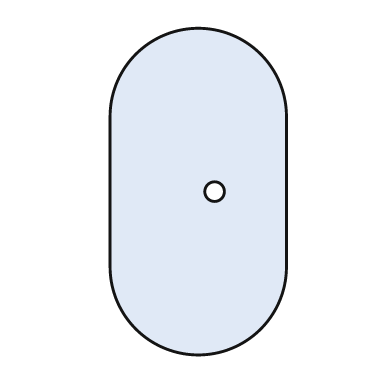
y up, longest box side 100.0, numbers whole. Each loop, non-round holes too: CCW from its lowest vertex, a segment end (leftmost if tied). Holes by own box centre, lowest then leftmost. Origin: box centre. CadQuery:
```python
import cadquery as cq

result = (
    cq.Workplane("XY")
    .moveTo(-27.0, -23.0)
    .threePointArc((0.0, -50.0), (27.0, -23.0))
    .lineTo(27.0, 23.0)
    .threePointArc((0.0, 50.0), (-27.0, 23.0))
    .close()
    .moveTo(5.0, 0.0)
    .circle(3.0)
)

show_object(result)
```